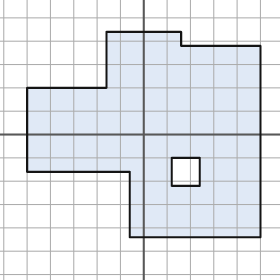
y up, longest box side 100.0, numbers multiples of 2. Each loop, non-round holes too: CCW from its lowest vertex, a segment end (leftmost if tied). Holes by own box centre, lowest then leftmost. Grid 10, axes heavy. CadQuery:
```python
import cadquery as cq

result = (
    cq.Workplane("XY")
    .moveTo(-6.0, -44.0)
    .lineTo(50.0, -44.0)
    .lineTo(50.0, 38.0)
    .lineTo(16.0, 38.0)
    .lineTo(16.0, 44.0)
    .lineTo(-16.0, 44.0)
    .lineTo(-16.0, 20.0)
    .lineTo(-50.0, 20.0)
    .lineTo(-50.0, -16.0)
    .lineTo(-6.0, -16.0)
    .close()
    .moveTo(12.0, -22.0)
    .lineTo(24.0, -22.0)
    .lineTo(24.0, -10.0)
    .lineTo(12.0, -10.0)
    .close()
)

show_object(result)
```